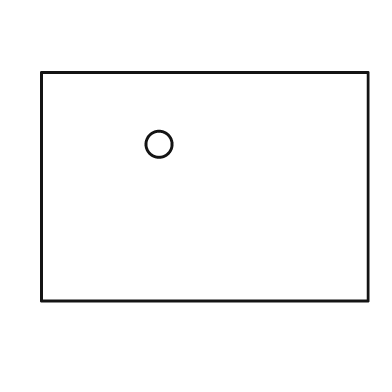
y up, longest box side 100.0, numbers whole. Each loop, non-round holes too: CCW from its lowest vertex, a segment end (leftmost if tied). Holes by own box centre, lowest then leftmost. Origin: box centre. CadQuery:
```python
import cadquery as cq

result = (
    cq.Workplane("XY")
    .moveTo(-50.0, -35.0)
    .lineTo(50.0, -35.0)
    .lineTo(50.0, 35.0)
    .lineTo(-50.0, 35.0)
    .close()
    .moveTo(-14.0, 13.0)
    .circle(4.0)
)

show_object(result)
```